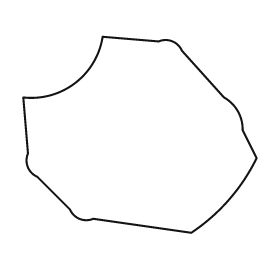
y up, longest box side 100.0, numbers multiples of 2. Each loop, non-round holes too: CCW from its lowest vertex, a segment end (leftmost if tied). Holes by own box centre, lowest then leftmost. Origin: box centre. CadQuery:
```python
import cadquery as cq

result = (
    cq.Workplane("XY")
    .moveTo(22.0, -42.0)
    .threePointArc((38.0, -28.0), (50.0, -10.0))
    .lineTo(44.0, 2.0)
    .threePointArc((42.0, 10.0), (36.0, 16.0))
    .lineTo(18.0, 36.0)
    .threePointArc((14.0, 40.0), (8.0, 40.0))
    .lineTo(-16.0, 42.0)
    .threePointArc((-28.0, 22.0), (-50.0, 16.0))
    .lineTo(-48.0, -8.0)
    .threePointArc((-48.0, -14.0), (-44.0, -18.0))
    .lineTo(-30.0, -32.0)
    .threePointArc((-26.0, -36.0), (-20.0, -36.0))
    .close()
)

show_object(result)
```